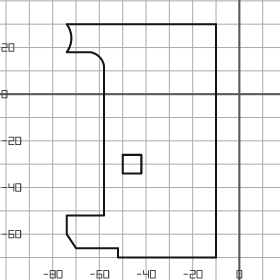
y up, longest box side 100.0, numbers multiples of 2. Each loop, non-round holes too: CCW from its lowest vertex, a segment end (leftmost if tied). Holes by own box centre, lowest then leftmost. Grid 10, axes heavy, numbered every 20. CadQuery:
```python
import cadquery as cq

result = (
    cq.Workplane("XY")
    .moveTo(-52.0, -70.0)
    .lineTo(-10.0, -70.0)
    .lineTo(-10.0, 30.0)
    .lineTo(-74.0, 30.0)
    .threePointArc((-72.0, 24.0), (-74.0, 18.0))
    .lineTo(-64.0, 18.0)
    .threePointArc((-60.0, 16.0), (-58.0, 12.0))
    .lineTo(-58.0, -52.0)
    .lineTo(-74.0, -52.0)
    .lineTo(-74.0, -60.0)
    .lineTo(-70.0, -66.0)
    .lineTo(-52.0, -66.0)
    .close()
    .moveTo(-50.0, -34.0)
    .lineTo(-42.0, -34.0)
    .lineTo(-42.0, -26.0)
    .lineTo(-50.0, -26.0)
    .close()
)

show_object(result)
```